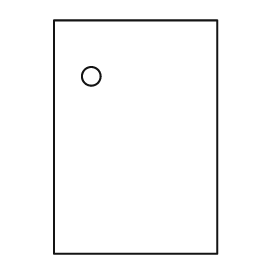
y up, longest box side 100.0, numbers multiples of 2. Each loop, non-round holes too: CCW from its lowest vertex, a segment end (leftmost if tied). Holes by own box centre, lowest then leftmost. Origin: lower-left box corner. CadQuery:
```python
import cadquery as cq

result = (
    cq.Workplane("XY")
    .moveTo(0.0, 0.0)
    .lineTo(70.0, 0.0)
    .lineTo(70.0, 100.0)
    .lineTo(0.0, 100.0)
    .close()
    .moveTo(16.0, 76.0)
    .circle(4.0)
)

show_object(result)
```